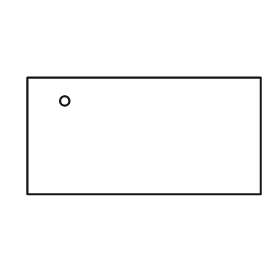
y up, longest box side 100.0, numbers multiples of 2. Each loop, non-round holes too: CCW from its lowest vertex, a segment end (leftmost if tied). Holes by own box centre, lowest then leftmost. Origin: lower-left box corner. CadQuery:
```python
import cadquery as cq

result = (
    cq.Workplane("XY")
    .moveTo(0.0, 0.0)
    .lineTo(100.0, 0.0)
    .lineTo(100.0, 50.0)
    .lineTo(0.0, 50.0)
    .close()
    .moveTo(16.0, 40.0)
    .circle(2.0)
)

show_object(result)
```